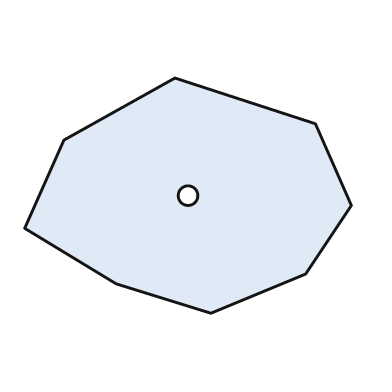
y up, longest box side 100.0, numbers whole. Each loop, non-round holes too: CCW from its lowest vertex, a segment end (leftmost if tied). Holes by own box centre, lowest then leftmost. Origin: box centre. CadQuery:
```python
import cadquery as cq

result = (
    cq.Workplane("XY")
    .moveTo(7.0, -36.0)
    .lineTo(36.0, -24.0)
    .lineTo(50.0, -3.0)
    .lineTo(39.0, 22.0)
    .lineTo(-4.0, 36.0)
    .lineTo(-38.0, 17.0)
    .lineTo(-50.0, -10.0)
    .lineTo(-22.0, -27.0)
    .close()
    .moveTo(0.0, 0.0)
    .circle(3.0)
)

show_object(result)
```